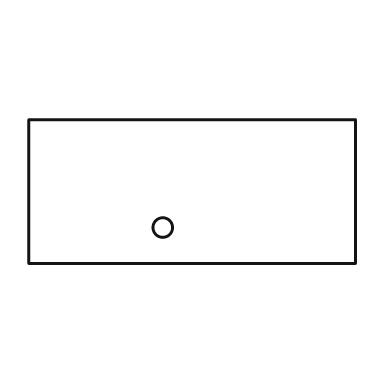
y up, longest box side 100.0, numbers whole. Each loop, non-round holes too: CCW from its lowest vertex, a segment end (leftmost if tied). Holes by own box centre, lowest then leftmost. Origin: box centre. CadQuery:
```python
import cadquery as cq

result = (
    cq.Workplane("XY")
    .moveTo(-50.0, -22.0)
    .lineTo(50.0, -22.0)
    .lineTo(50.0, 22.0)
    .lineTo(-50.0, 22.0)
    .close()
    .moveTo(-9.0, -11.0)
    .circle(3.0)
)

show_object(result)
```